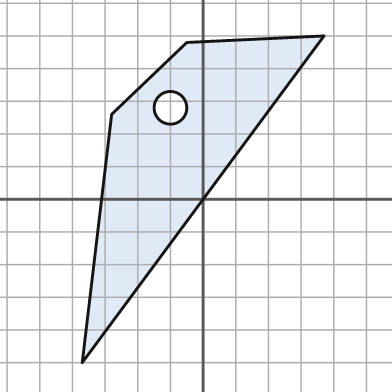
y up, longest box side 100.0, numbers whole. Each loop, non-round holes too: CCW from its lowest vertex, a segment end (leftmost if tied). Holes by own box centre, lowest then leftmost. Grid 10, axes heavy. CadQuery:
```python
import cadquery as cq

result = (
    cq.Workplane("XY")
    .moveTo(-37.0, -50.0)
    .lineTo(37.0, 50.0)
    .lineTo(-5.0, 48.0)
    .lineTo(-28.0, 26.0)
    .close()
    .moveTo(-10.0, 28.0)
    .circle(5.0)
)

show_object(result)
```